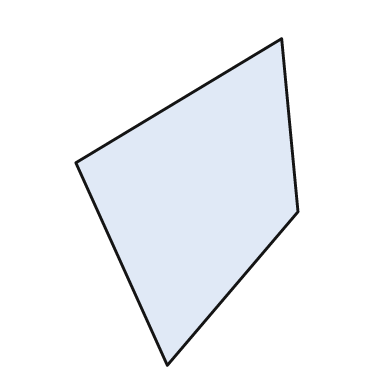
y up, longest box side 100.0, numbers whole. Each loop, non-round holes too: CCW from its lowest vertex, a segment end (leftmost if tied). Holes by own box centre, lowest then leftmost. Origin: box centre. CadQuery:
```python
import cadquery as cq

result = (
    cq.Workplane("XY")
    .moveTo(-6.0, -50.0)
    .lineTo(34.0, -3.0)
    .lineTo(29.0, 50.0)
    .lineTo(-34.0, 12.0)
    .close()
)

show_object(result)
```